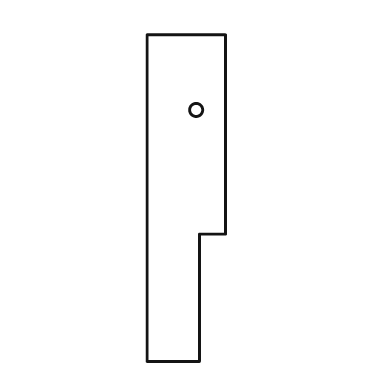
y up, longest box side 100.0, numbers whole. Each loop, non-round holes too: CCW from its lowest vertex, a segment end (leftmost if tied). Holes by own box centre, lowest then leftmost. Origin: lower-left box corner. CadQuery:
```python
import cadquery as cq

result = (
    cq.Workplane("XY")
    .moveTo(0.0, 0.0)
    .lineTo(16.0, 0.0)
    .lineTo(16.0, 39.0)
    .lineTo(24.0, 39.0)
    .lineTo(24.0, 100.0)
    .lineTo(0.0, 100.0)
    .close()
    .moveTo(15.0, 77.0)
    .circle(2.0)
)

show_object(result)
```